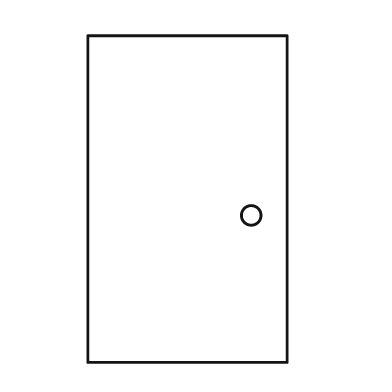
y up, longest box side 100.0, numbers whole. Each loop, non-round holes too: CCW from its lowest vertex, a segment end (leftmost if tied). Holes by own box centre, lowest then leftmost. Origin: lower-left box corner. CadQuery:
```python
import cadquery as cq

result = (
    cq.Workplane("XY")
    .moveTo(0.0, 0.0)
    .lineTo(61.0, 0.0)
    .lineTo(61.0, 100.0)
    .lineTo(0.0, 100.0)
    .close()
    .moveTo(50.0, 45.0)
    .circle(3.0)
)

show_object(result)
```